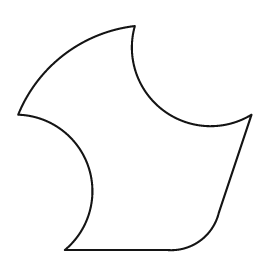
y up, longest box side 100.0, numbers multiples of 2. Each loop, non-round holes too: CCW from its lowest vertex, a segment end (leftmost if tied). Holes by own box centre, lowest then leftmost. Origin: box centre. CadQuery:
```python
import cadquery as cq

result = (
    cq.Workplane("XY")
    .moveTo(-30.0, -48.0)
    .lineTo(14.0, -48.0)
    .threePointArc((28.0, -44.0), (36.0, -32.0))
    .lineTo(50.0, 10.0)
    .threePointArc((12.0, 12.0), (0.0, 48.0))
    .threePointArc((-30.0, 36.0), (-50.0, 10.0))
    .threePointArc((-20.0, -12.0), (-30.0, -48.0))
    .close()
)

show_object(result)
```